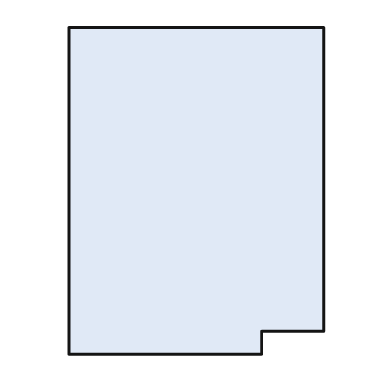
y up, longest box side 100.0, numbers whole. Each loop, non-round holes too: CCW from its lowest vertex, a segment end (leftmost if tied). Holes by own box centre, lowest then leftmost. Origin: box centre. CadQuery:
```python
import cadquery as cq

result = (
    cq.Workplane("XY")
    .moveTo(-39.0, -50.0)
    .lineTo(20.0, -50.0)
    .lineTo(20.0, -43.0)
    .lineTo(39.0, -43.0)
    .lineTo(39.0, 50.0)
    .lineTo(-39.0, 50.0)
    .close()
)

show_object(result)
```